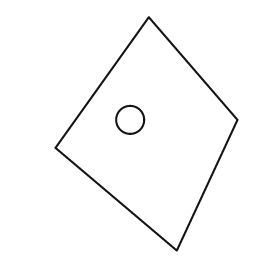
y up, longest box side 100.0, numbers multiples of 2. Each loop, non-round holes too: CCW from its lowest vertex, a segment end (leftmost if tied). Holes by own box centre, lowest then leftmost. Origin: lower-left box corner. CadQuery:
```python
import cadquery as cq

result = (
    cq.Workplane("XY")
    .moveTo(52.0, 0.0)
    .lineTo(78.0, 56.0)
    .lineTo(40.0, 100.0)
    .lineTo(0.0, 44.0)
    .close()
    .moveTo(32.0, 56.0)
    .circle(6.0)
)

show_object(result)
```